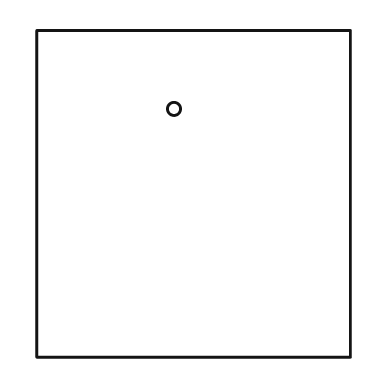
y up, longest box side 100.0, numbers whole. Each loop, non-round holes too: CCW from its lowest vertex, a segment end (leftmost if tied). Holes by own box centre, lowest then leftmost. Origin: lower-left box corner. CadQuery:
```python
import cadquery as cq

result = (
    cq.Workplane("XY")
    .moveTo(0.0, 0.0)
    .lineTo(96.0, 0.0)
    .lineTo(96.0, 100.0)
    .lineTo(0.0, 100.0)
    .close()
    .moveTo(42.0, 76.0)
    .circle(2.0)
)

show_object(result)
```